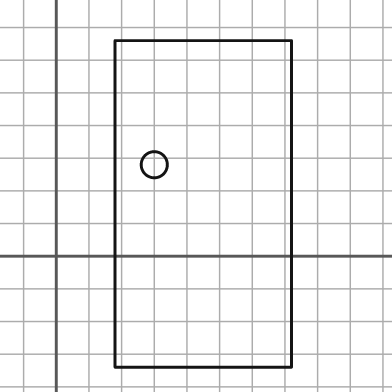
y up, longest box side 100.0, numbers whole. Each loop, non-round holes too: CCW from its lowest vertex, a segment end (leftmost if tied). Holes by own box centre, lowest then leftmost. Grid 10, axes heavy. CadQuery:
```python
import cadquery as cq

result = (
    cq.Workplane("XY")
    .moveTo(18.0, -34.0)
    .lineTo(72.0, -34.0)
    .lineTo(72.0, 66.0)
    .lineTo(18.0, 66.0)
    .close()
    .moveTo(30.0, 28.0)
    .circle(4.0)
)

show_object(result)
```